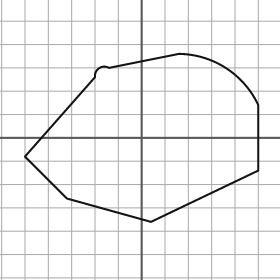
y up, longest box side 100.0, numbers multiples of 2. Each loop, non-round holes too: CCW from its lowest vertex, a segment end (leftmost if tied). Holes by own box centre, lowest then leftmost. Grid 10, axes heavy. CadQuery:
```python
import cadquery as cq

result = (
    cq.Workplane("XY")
    .moveTo(4.0, -36.0)
    .lineTo(50.0, -14.0)
    .lineTo(50.0, 14.0)
    .threePointArc((36.0, 30.0), (16.0, 36.0))
    .lineTo(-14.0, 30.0)
    .threePointArc((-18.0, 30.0), (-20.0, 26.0))
    .lineTo(-50.0, -8.0)
    .lineTo(-32.0, -26.0)
    .close()
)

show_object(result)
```